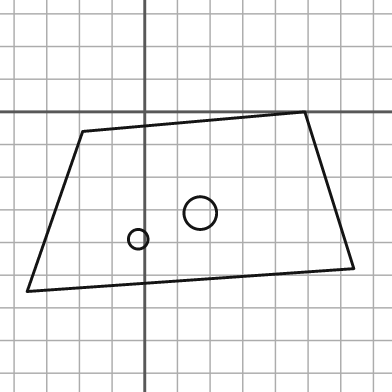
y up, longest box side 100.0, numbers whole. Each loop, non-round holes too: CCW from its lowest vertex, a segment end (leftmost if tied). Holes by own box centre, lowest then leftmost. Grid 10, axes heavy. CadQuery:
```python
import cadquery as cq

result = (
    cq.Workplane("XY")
    .moveTo(-36.0, -55.0)
    .lineTo(64.0, -48.0)
    .lineTo(49.0, 0.0)
    .lineTo(-19.0, -6.0)
    .close()
    .moveTo(-2.0, -39.0)
    .circle(3.0)
    .moveTo(17.0, -31.0)
    .circle(5.0)
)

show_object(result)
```